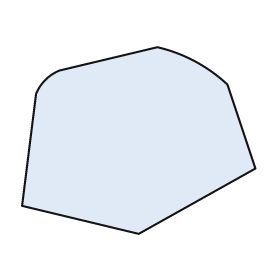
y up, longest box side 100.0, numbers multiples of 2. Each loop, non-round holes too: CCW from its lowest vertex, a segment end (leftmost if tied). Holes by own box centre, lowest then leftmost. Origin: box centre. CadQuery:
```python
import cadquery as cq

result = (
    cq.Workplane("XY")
    .moveTo(0.0, -40.0)
    .lineTo(50.0, -12.0)
    .lineTo(38.0, 24.0)
    .threePointArc((24.0, 34.0), (8.0, 40.0))
    .lineTo(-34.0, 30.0)
    .threePointArc((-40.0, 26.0), (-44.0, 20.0))
    .lineTo(-50.0, -28.0)
    .close()
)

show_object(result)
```